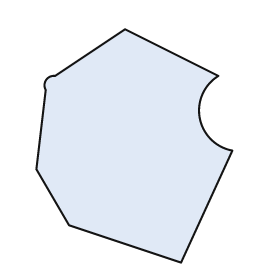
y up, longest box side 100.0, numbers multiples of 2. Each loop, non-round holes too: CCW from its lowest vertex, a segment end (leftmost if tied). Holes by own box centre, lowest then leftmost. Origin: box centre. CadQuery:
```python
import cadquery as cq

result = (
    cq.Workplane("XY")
    .moveTo(20.0, -50.0)
    .lineTo(42.0, -2.0)
    .threePointArc((28.0, 12.0), (36.0, 30.0))
    .lineTo(-4.0, 50.0)
    .lineTo(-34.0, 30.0)
    .threePointArc((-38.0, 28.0), (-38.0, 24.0))
    .lineTo(-42.0, -10.0)
    .lineTo(-28.0, -34.0)
    .close()
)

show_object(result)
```